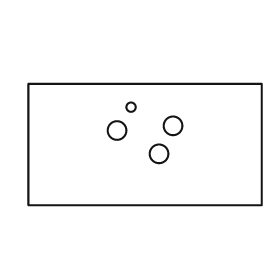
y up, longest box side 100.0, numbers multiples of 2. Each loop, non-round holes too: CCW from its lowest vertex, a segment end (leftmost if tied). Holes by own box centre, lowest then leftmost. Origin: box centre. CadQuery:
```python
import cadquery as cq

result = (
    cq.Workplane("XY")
    .moveTo(-50.0, -26.0)
    .lineTo(50.0, -26.0)
    .lineTo(50.0, 26.0)
    .lineTo(-50.0, 26.0)
    .close()
    .moveTo(6.0, -4.0)
    .circle(4.0)
    .moveTo(-12.0, 6.0)
    .circle(4.0)
    .moveTo(12.0, 8.0)
    .circle(4.0)
    .moveTo(-6.0, 16.0)
    .circle(2.0)
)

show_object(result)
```